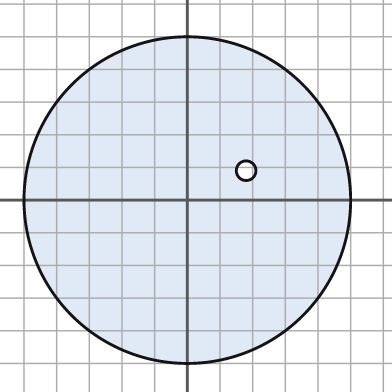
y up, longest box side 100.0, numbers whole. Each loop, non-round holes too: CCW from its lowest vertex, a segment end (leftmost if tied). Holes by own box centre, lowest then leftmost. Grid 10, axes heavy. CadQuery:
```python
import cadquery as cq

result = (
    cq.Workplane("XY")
    .moveTo(0.0, 0.0)
    .circle(50.0)
    .moveTo(18.0, 9.0)
    .circle(3.0)
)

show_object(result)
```